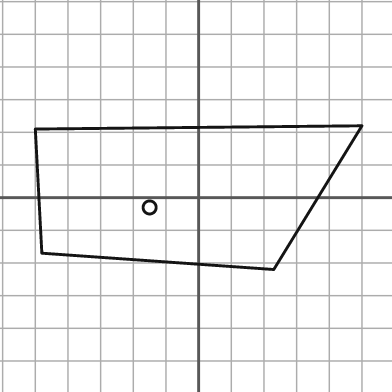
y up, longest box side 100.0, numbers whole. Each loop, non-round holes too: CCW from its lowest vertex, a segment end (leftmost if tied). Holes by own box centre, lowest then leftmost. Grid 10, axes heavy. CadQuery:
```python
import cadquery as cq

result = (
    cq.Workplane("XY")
    .moveTo(23.0, -22.0)
    .lineTo(50.0, 22.0)
    .lineTo(-50.0, 21.0)
    .lineTo(-48.0, -17.0)
    .close()
    .moveTo(-15.0, -3.0)
    .circle(2.0)
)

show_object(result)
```